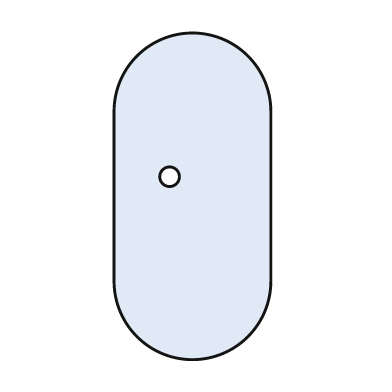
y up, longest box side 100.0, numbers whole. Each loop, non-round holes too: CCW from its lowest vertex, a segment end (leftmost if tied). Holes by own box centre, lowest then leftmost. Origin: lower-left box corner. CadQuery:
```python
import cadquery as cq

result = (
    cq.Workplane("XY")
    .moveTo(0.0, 24.0)
    .threePointArc((24.0, 0.0), (48.0, 24.0))
    .lineTo(48.0, 76.0)
    .threePointArc((24.0, 100.0), (0.0, 76.0))
    .close()
    .moveTo(17.0, 56.0)
    .circle(3.0)
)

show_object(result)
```